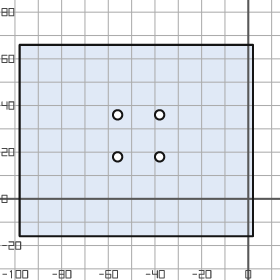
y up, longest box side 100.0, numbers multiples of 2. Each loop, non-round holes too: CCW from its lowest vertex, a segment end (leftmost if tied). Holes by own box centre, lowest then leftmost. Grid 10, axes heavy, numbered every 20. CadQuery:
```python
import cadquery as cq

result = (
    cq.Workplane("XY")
    .moveTo(-98.0, -16.0)
    .lineTo(2.0, -16.0)
    .lineTo(2.0, 66.0)
    .lineTo(-98.0, 66.0)
    .close()
    .moveTo(-56.0, 18.0)
    .circle(2.0)
    .moveTo(-38.0, 18.0)
    .circle(2.0)
    .moveTo(-56.0, 36.0)
    .circle(2.0)
    .moveTo(-38.0, 36.0)
    .circle(2.0)
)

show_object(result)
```